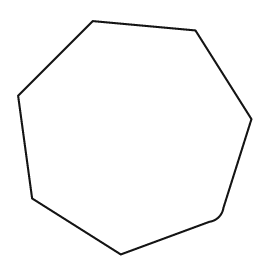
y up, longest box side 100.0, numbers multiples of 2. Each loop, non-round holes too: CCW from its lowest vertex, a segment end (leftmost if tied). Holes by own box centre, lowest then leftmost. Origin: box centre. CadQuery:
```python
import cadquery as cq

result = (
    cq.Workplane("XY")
    .moveTo(-6.0, -50.0)
    .lineTo(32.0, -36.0)
    .threePointArc((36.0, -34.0), (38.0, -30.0))
    .lineTo(50.0, 8.0)
    .lineTo(26.0, 46.0)
    .lineTo(-18.0, 50.0)
    .lineTo(-50.0, 18.0)
    .lineTo(-44.0, -26.0)
    .close()
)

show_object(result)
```